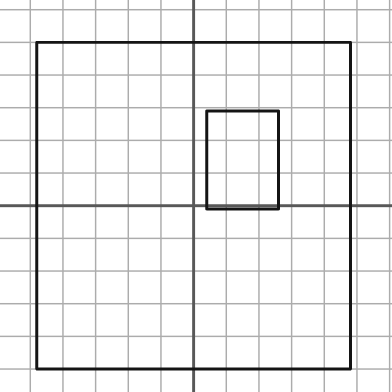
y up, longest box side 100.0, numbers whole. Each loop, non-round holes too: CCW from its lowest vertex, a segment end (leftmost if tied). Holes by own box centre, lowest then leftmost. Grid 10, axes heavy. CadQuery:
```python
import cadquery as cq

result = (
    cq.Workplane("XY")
    .moveTo(-48.0, -50.0)
    .lineTo(48.0, -50.0)
    .lineTo(48.0, 50.0)
    .lineTo(-48.0, 50.0)
    .close()
    .moveTo(4.0, -1.0)
    .lineTo(26.0, -1.0)
    .lineTo(26.0, 29.0)
    .lineTo(4.0, 29.0)
    .close()
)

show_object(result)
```